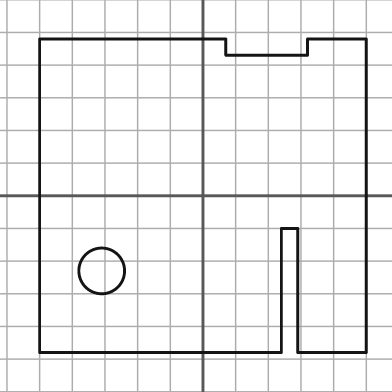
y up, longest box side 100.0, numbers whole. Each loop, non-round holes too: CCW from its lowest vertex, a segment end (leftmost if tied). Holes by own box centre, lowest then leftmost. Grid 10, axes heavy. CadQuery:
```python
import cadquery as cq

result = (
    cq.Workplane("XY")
    .moveTo(-50.0, -48.0)
    .lineTo(24.0, -48.0)
    .lineTo(24.0, -10.0)
    .lineTo(29.0, -10.0)
    .lineTo(29.0, -48.0)
    .lineTo(50.0, -48.0)
    .lineTo(50.0, 48.0)
    .lineTo(32.0, 48.0)
    .lineTo(32.0, 43.0)
    .lineTo(7.0, 43.0)
    .lineTo(7.0, 48.0)
    .lineTo(-50.0, 48.0)
    .close()
    .moveTo(-31.0, -23.0)
    .circle(7.0)
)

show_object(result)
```